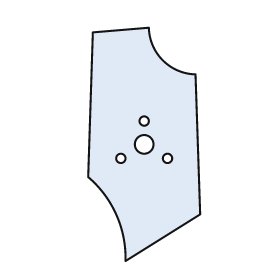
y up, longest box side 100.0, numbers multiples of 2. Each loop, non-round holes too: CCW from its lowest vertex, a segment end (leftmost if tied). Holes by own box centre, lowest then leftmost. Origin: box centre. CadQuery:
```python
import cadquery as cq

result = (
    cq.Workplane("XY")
    .moveTo(-8.0, -50.0)
    .lineTo(24.0, -30.0)
    .lineTo(22.0, 30.0)
    .threePointArc((8.0, 36.0), (2.0, 50.0))
    .lineTo(-22.0, 48.0)
    .lineTo(-24.0, -14.0)
    .threePointArc((-12.0, -30.0), (-8.0, -50.0))
    .close()
    .moveTo(-10.0, -6.0)
    .circle(2.0)
    .moveTo(10.0, -6.0)
    .circle(2.0)
    .moveTo(0.0, 0.0)
    .circle(4.0)
    .moveTo(0.0, 10.0)
    .circle(2.0)
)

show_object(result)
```